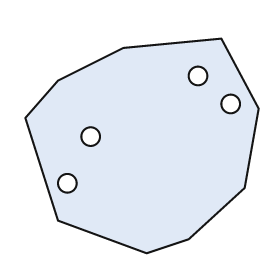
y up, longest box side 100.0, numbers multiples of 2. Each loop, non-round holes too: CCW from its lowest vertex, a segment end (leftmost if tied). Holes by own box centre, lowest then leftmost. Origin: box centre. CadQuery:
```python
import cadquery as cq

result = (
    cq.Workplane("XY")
    .moveTo(2.0, -46.0)
    .lineTo(20.0, -40.0)
    .lineTo(44.0, -18.0)
    .lineTo(50.0, 16.0)
    .lineTo(34.0, 46.0)
    .lineTo(-8.0, 42.0)
    .lineTo(-36.0, 28.0)
    .lineTo(-50.0, 12.0)
    .lineTo(-36.0, -32.0)
    .close()
    .moveTo(-32.0, -16.0)
    .circle(4.0)
    .moveTo(-22.0, 4.0)
    .circle(4.0)
    .moveTo(38.0, 18.0)
    .circle(4.0)
    .moveTo(24.0, 30.0)
    .circle(4.0)
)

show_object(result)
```